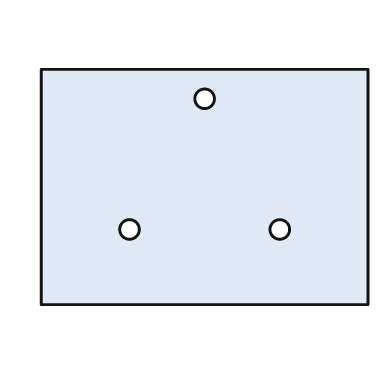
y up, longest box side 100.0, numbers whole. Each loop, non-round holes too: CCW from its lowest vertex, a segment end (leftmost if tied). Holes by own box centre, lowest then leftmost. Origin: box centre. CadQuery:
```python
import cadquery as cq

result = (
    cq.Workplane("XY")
    .moveTo(-50.0, -36.0)
    .lineTo(50.0, -36.0)
    .lineTo(50.0, 36.0)
    .lineTo(-50.0, 36.0)
    .close()
    .moveTo(-23.0, -13.0)
    .circle(3.0)
    .moveTo(23.0, -13.0)
    .circle(3.0)
    .moveTo(0.0, 27.0)
    .circle(3.0)
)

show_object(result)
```